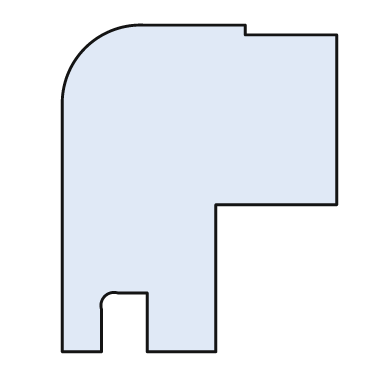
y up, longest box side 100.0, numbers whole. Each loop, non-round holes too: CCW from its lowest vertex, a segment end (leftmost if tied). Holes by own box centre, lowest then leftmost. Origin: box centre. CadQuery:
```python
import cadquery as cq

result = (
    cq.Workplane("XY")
    .moveTo(-42.0, -50.0)
    .lineTo(-30.0, -50.0)
    .lineTo(-30.0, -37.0)
    .threePointArc((-29.0, -33.0), (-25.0, -32.0))
    .lineTo(-16.0, -32.0)
    .lineTo(-16.0, -50.0)
    .lineTo(5.0, -50.0)
    .lineTo(5.0, -5.0)
    .lineTo(42.0, -5.0)
    .lineTo(42.0, 47.0)
    .lineTo(14.0, 47.0)
    .lineTo(14.0, 50.0)
    .lineTo(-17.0, 50.0)
    .threePointArc((-35.0, 43.0), (-42.0, 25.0))
    .close()
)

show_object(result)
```